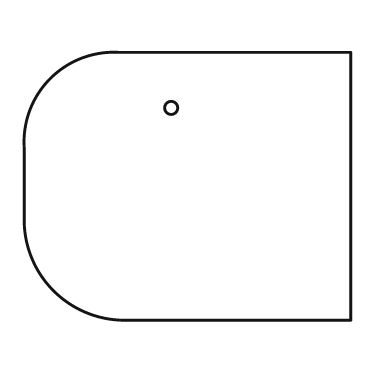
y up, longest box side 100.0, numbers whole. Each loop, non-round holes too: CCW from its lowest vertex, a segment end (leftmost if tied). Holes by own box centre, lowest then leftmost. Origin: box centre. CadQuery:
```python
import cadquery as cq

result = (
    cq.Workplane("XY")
    .moveTo(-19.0, -41.0)
    .lineTo(50.0, -41.0)
    .lineTo(50.0, 41.0)
    .lineTo(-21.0, 41.0)
    .threePointArc((-42.0, 33.0), (-50.0, 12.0))
    .lineTo(-50.0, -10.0)
    .threePointArc((-41.0, -32.0), (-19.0, -41.0))
    .close()
    .moveTo(-5.0, 24.0)
    .circle(2.0)
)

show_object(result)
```